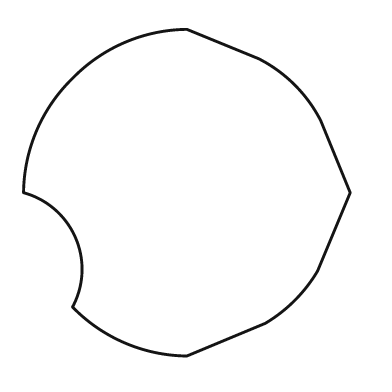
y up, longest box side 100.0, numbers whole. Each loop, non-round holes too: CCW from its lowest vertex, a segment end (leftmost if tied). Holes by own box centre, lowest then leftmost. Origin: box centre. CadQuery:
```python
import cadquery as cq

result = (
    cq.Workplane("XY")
    .moveTo(0.0, -50.0)
    .lineTo(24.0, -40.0)
    .threePointArc((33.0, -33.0), (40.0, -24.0))
    .lineTo(50.0, 0.0)
    .lineTo(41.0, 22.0)
    .threePointArc((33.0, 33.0), (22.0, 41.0))
    .lineTo(0.0, 50.0)
    .threePointArc((-19.0, 46.0), (-35.0, 35.0))
    .threePointArc((-46.0, 19.0), (-50.0, 0.0))
    .threePointArc((-34.0, -14.0), (-35.0, -35.0))
    .threePointArc((-19.0, -46.0), (0.0, -50.0))
    .close()
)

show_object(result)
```